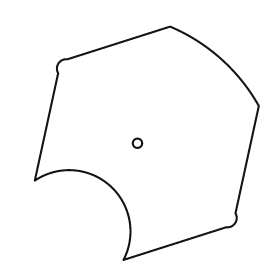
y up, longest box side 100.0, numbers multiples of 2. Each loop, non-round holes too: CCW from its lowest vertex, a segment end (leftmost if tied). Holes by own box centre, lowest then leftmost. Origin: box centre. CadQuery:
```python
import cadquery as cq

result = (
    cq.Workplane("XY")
    .moveTo(-10.0, -50.0)
    .lineTo(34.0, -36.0)
    .threePointArc((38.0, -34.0), (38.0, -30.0))
    .lineTo(48.0, 16.0)
    .threePointArc((32.0, 36.0), (10.0, 50.0))
    .lineTo(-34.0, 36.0)
    .threePointArc((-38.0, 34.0), (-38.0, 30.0))
    .lineTo(-48.0, -16.0)
    .threePointArc((-16.0, -18.0), (-10.0, -50.0))
    .close()
    .moveTo(-4.0, 0.0)
    .circle(2.0)
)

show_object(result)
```